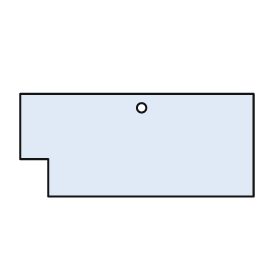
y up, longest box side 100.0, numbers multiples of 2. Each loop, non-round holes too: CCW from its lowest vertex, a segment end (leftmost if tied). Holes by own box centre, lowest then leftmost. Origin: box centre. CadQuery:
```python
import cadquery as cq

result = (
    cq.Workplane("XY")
    .moveTo(-38.0, -22.0)
    .lineTo(50.0, -22.0)
    .lineTo(50.0, 22.0)
    .lineTo(-50.0, 22.0)
    .lineTo(-50.0, -6.0)
    .lineTo(-38.0, -6.0)
    .close()
    .moveTo(2.0, 16.0)
    .circle(2.0)
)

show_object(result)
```